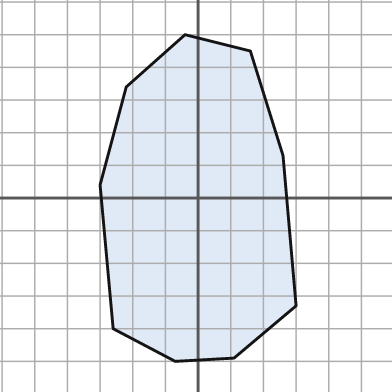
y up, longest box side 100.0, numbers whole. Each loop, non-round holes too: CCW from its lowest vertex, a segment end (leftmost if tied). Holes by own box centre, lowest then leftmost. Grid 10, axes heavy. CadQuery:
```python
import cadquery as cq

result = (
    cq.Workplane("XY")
    .moveTo(-7.0, -50.0)
    .lineTo(11.0, -49.0)
    .lineTo(30.0, -33.0)
    .lineTo(26.0, 13.0)
    .lineTo(16.0, 45.0)
    .lineTo(-4.0, 50.0)
    .lineTo(-22.0, 34.0)
    .lineTo(-30.0, 4.0)
    .lineTo(-26.0, -40.0)
    .close()
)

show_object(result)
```